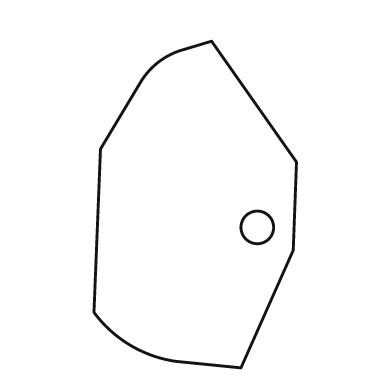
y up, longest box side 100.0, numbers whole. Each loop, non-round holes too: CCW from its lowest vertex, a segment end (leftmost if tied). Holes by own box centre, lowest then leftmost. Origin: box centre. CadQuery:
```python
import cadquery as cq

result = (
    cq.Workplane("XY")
    .moveTo(14.0, -50.0)
    .lineTo(30.0, -14.0)
    .lineTo(31.0, 13.0)
    .lineTo(5.0, 50.0)
    .lineTo(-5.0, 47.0)
    .threePointArc((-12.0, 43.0), (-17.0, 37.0))
    .lineTo(-29.0, 17.0)
    .lineTo(-31.0, -33.0)
    .threePointArc((-20.0, -43.0), (-6.0, -48.0))
    .close()
    .moveTo(19.0, -7.0)
    .circle(5.0)
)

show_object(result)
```